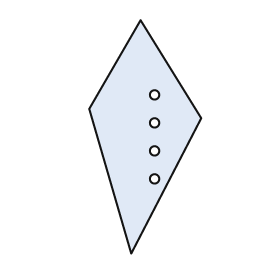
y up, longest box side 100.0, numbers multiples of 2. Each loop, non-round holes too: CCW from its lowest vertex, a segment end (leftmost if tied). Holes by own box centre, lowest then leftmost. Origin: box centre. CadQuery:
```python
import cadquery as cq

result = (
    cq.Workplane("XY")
    .moveTo(-6.0, -50.0)
    .lineTo(24.0, 8.0)
    .lineTo(-2.0, 50.0)
    .lineTo(-24.0, 12.0)
    .close()
    .moveTo(4.0, -18.0)
    .circle(2.0)
    .moveTo(4.0, -6.0)
    .circle(2.0)
    .moveTo(4.0, 6.0)
    .circle(2.0)
    .moveTo(4.0, 18.0)
    .circle(2.0)
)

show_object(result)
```